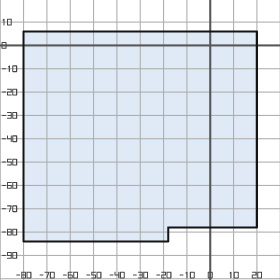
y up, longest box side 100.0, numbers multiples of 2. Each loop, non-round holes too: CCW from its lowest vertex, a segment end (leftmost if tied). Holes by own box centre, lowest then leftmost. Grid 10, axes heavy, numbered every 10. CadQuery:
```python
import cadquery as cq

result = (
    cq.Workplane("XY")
    .moveTo(-80.0, -84.0)
    .lineTo(-18.0, -84.0)
    .lineTo(-18.0, -78.0)
    .lineTo(20.0, -78.0)
    .lineTo(20.0, 6.0)
    .lineTo(-80.0, 6.0)
    .close()
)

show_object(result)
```